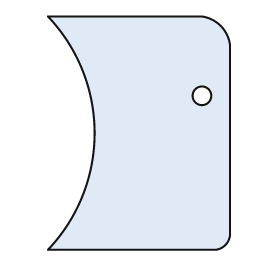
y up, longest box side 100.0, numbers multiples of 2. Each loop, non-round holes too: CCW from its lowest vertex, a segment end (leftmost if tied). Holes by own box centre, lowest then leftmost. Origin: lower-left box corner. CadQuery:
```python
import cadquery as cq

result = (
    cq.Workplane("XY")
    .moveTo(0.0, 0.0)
    .lineTo(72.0, 0.0)
    .threePointArc((76.0, 2.0), (78.0, 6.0))
    .lineTo(78.0, 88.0)
    .threePointArc((74.0, 96.0), (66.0, 100.0))
    .lineTo(0.0, 100.0)
    .threePointArc((20.0, 50.0), (0.0, 0.0))
    .close()
    .moveTo(66.0, 66.0)
    .circle(4.0)
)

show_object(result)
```